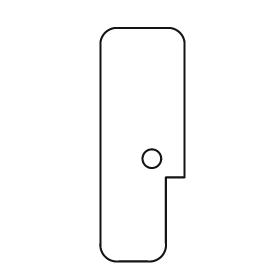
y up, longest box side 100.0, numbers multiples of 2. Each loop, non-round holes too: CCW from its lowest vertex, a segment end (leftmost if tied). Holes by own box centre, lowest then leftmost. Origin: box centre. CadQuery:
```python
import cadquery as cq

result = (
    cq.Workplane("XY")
    .moveTo(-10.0, -50.0)
    .lineTo(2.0, -50.0)
    .threePointArc((8.0, -48.0), (10.0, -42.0))
    .lineTo(10.0, -14.0)
    .lineTo(18.0, -14.0)
    .lineTo(18.0, 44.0)
    .threePointArc((16.0, 48.0), (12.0, 50.0))
    .lineTo(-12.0, 50.0)
    .threePointArc((-16.0, 48.0), (-18.0, 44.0))
    .lineTo(-18.0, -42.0)
    .threePointArc((-16.0, -48.0), (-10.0, -50.0))
    .close()
    .moveTo(4.0, -6.0)
    .circle(4.0)
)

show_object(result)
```